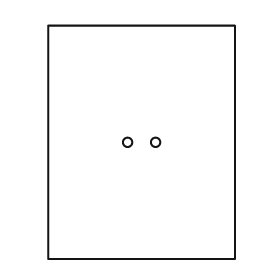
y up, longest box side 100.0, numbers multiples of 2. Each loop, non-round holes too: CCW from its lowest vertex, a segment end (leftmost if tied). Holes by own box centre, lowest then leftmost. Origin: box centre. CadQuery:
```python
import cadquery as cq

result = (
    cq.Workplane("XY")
    .moveTo(-40.0, -50.0)
    .lineTo(40.0, -50.0)
    .lineTo(40.0, 50.0)
    .lineTo(-40.0, 50.0)
    .close()
    .moveTo(-6.0, 0.0)
    .circle(2.0)
    .moveTo(6.0, 0.0)
    .circle(2.0)
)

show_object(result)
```